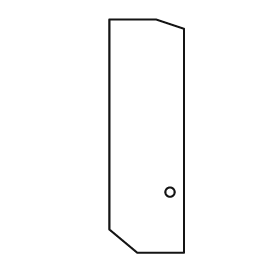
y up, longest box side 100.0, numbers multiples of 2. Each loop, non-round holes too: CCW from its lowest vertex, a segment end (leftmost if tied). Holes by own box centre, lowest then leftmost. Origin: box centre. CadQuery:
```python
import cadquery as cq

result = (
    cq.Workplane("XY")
    .moveTo(-4.0, -50.0)
    .lineTo(16.0, -50.0)
    .lineTo(16.0, 46.0)
    .lineTo(4.0, 50.0)
    .lineTo(-16.0, 50.0)
    .lineTo(-16.0, -40.0)
    .close()
    .moveTo(10.0, -24.0)
    .circle(2.0)
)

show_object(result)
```